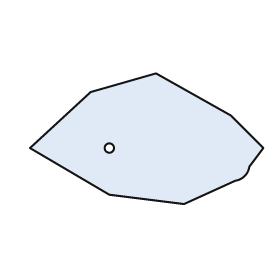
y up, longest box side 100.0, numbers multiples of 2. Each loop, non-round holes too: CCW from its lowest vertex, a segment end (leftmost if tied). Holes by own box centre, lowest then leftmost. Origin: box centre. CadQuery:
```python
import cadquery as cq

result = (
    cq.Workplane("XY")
    .moveTo(16.0, -28.0)
    .lineTo(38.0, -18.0)
    .threePointArc((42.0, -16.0), (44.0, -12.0))
    .lineTo(50.0, -4.0)
    .lineTo(36.0, 10.0)
    .lineTo(4.0, 28.0)
    .lineTo(-24.0, 20.0)
    .lineTo(-50.0, -4.0)
    .lineTo(-16.0, -24.0)
    .close()
    .moveTo(-16.0, -4.0)
    .circle(2.0)
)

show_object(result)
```